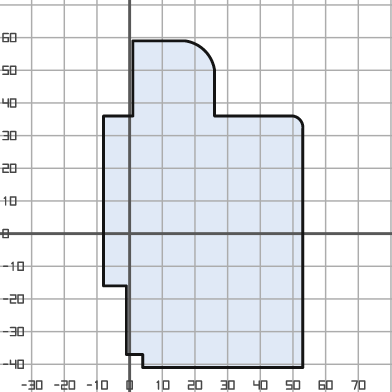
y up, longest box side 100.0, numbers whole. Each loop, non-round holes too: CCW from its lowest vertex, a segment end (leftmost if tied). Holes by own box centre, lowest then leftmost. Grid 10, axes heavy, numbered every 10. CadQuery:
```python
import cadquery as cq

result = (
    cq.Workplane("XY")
    .moveTo(4.0, -41.0)
    .lineTo(53.0, -41.0)
    .lineTo(53.0, 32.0)
    .threePointArc((52.0, 35.0), (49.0, 36.0))
    .lineTo(26.0, 36.0)
    .lineTo(26.0, 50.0)
    .threePointArc((23.0, 56.0), (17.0, 59.0))
    .lineTo(1.0, 59.0)
    .lineTo(1.0, 36.0)
    .lineTo(-8.0, 36.0)
    .lineTo(-8.0, -16.0)
    .lineTo(-1.0, -16.0)
    .lineTo(-1.0, -37.0)
    .lineTo(4.0, -37.0)
    .close()
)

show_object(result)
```